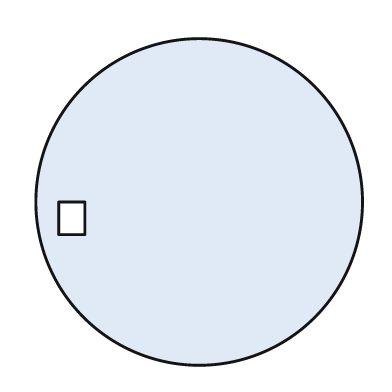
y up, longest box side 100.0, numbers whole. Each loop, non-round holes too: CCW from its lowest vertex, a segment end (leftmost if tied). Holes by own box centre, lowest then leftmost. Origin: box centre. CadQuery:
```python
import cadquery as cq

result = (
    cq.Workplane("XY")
    .moveTo(0.0, 0.0)
    .circle(50.0)
    .moveTo(-43.0, -10.0)
    .lineTo(-35.0, -10.0)
    .lineTo(-35.0, 0.0)
    .lineTo(-43.0, 0.0)
    .close()
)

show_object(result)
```